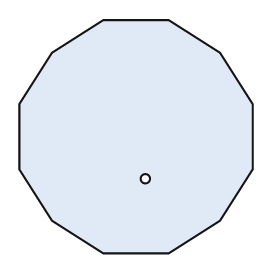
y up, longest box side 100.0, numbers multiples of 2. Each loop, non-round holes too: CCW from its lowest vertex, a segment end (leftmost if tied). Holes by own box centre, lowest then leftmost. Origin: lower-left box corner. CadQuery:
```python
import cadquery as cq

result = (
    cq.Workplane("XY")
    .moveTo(36.0, 0.0)
    .lineTo(64.0, 0.0)
    .lineTo(86.0, 14.0)
    .lineTo(100.0, 36.0)
    .lineTo(100.0, 64.0)
    .lineTo(86.0, 86.0)
    .lineTo(64.0, 100.0)
    .lineTo(36.0, 100.0)
    .lineTo(14.0, 86.0)
    .lineTo(0.0, 64.0)
    .lineTo(0.0, 36.0)
    .lineTo(14.0, 14.0)
    .close()
    .moveTo(54.0, 32.0)
    .circle(2.0)
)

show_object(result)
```